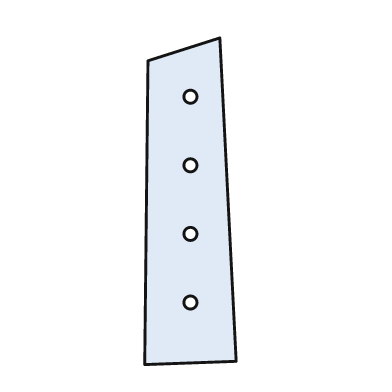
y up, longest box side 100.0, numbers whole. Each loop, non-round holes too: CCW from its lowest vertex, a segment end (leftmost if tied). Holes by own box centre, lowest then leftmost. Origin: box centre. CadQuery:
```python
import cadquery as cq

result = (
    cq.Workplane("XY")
    .moveTo(-14.0, -50.0)
    .lineTo(14.0, -49.0)
    .lineTo(9.0, 50.0)
    .lineTo(-13.0, 43.0)
    .close()
    .moveTo(0.0, -31.0)
    .circle(2.0)
    .moveTo(0.0, -10.0)
    .circle(2.0)
    .moveTo(0.0, 11.0)
    .circle(2.0)
    .moveTo(0.0, 32.0)
    .circle(2.0)
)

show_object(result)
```